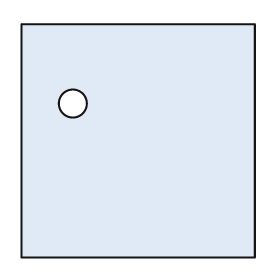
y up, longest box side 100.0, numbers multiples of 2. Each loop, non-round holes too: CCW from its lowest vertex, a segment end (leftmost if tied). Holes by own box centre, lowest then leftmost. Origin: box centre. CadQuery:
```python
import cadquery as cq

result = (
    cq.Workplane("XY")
    .moveTo(-50.0, -50.0)
    .lineTo(50.0, -50.0)
    .lineTo(50.0, 50.0)
    .lineTo(-50.0, 50.0)
    .close()
    .moveTo(-28.0, 16.0)
    .circle(6.0)
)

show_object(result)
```